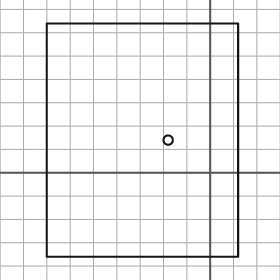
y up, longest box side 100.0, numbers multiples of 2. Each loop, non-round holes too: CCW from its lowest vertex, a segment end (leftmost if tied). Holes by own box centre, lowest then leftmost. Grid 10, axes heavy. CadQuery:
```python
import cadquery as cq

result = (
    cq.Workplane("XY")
    .moveTo(-70.0, -36.0)
    .lineTo(12.0, -36.0)
    .lineTo(12.0, 64.0)
    .lineTo(-70.0, 64.0)
    .close()
    .moveTo(-18.0, 14.0)
    .circle(2.0)
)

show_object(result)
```